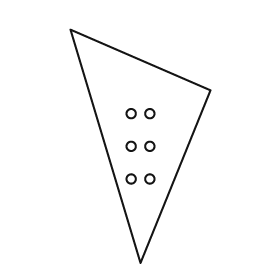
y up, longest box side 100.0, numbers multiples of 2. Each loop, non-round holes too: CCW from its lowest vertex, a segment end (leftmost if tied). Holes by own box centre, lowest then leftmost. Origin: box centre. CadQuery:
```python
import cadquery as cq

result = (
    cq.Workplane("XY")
    .moveTo(0.0, -50.0)
    .lineTo(30.0, 24.0)
    .lineTo(-30.0, 50.0)
    .close()
    .moveTo(-4.0, -14.0)
    .circle(2.0)
    .moveTo(4.0, -14.0)
    .circle(2.0)
    .moveTo(-4.0, 0.0)
    .circle(2.0)
    .moveTo(4.0, 0.0)
    .circle(2.0)
    .moveTo(-4.0, 14.0)
    .circle(2.0)
    .moveTo(4.0, 14.0)
    .circle(2.0)
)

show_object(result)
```